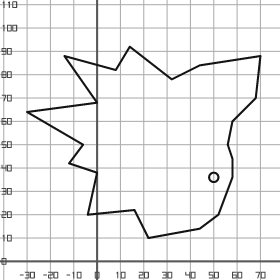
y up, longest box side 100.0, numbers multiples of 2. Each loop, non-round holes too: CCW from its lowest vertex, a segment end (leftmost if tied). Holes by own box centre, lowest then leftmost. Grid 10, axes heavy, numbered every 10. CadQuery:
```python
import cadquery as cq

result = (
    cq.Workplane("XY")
    .moveTo(22.0, 10.0)
    .lineTo(44.0, 14.0)
    .lineTo(52.0, 20.0)
    .lineTo(58.0, 36.0)
    .lineTo(58.0, 44.0)
    .lineTo(56.0, 50.0)
    .lineTo(58.0, 60.0)
    .lineTo(68.0, 70.0)
    .lineTo(70.0, 88.0)
    .lineTo(44.0, 84.0)
    .lineTo(32.0, 78.0)
    .lineTo(14.0, 92.0)
    .lineTo(8.0, 82.0)
    .lineTo(-14.0, 88.0)
    .lineTo(0.0, 68.0)
    .lineTo(-30.0, 64.0)
    .lineTo(-6.0, 50.0)
    .lineTo(-12.0, 42.0)
    .lineTo(0.0, 38.0)
    .lineTo(-4.0, 20.0)
    .lineTo(16.0, 22.0)
    .close()
    .moveTo(50.0, 36.0)
    .circle(2.0)
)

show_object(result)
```